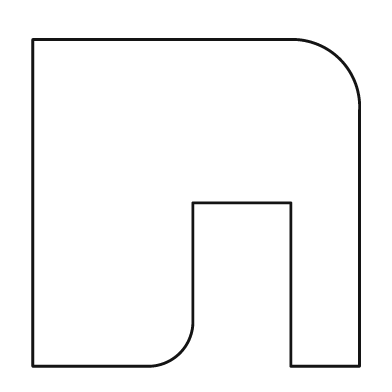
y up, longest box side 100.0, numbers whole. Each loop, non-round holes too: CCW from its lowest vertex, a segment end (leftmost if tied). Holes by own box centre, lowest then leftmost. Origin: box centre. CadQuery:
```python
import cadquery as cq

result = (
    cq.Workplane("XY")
    .moveTo(-50.0, -50.0)
    .lineTo(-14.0, -50.0)
    .threePointArc((-5.0, -46.0), (-1.0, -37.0))
    .lineTo(-1.0, 0.0)
    .lineTo(29.0, 0.0)
    .lineTo(29.0, -50.0)
    .lineTo(50.0, -50.0)
    .lineTo(50.0, 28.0)
    .threePointArc((44.0, 44.0), (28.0, 50.0))
    .lineTo(-50.0, 50.0)
    .close()
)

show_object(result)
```